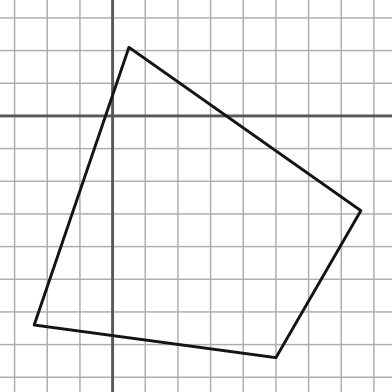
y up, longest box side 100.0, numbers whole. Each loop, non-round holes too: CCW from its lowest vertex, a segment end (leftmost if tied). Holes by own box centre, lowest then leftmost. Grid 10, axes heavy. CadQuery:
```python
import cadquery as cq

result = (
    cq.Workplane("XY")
    .moveTo(50.0, -74.0)
    .lineTo(76.0, -29.0)
    .lineTo(5.0, 21.0)
    .lineTo(-24.0, -64.0)
    .close()
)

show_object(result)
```